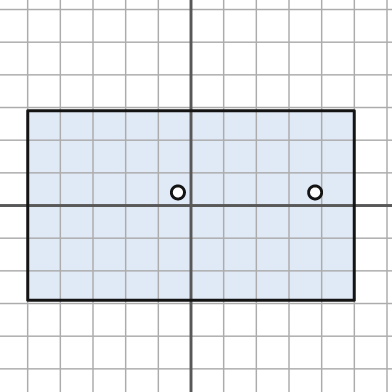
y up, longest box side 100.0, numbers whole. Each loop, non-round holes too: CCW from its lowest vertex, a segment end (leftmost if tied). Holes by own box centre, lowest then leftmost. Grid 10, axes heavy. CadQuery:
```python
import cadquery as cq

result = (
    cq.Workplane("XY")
    .moveTo(-50.0, -29.0)
    .lineTo(50.0, -29.0)
    .lineTo(50.0, 29.0)
    .lineTo(-50.0, 29.0)
    .close()
    .moveTo(-4.0, 4.0)
    .circle(2.0)
    .moveTo(38.0, 4.0)
    .circle(2.0)
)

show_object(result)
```